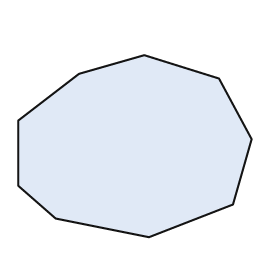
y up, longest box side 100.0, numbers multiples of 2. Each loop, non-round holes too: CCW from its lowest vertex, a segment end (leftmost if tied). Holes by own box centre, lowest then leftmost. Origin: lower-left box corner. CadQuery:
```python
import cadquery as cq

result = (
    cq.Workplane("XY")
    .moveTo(56.0, 0.0)
    .lineTo(92.0, 14.0)
    .lineTo(100.0, 42.0)
    .lineTo(86.0, 68.0)
    .lineTo(54.0, 78.0)
    .lineTo(26.0, 70.0)
    .lineTo(0.0, 50.0)
    .lineTo(0.0, 22.0)
    .lineTo(16.0, 8.0)
    .close()
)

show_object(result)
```